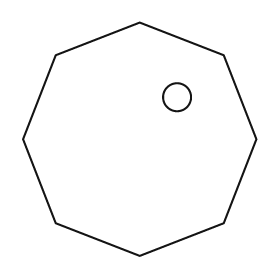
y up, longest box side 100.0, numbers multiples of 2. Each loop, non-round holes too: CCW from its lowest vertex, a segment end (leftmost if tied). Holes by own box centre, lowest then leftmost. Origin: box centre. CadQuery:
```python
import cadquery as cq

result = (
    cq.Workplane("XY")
    .moveTo(0.0, -50.0)
    .lineTo(36.0, -36.0)
    .lineTo(50.0, 0.0)
    .lineTo(36.0, 36.0)
    .lineTo(0.0, 50.0)
    .lineTo(-36.0, 36.0)
    .lineTo(-50.0, 0.0)
    .lineTo(-36.0, -36.0)
    .close()
    .moveTo(16.0, 18.0)
    .circle(6.0)
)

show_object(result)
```